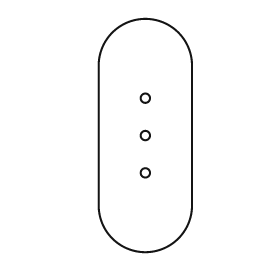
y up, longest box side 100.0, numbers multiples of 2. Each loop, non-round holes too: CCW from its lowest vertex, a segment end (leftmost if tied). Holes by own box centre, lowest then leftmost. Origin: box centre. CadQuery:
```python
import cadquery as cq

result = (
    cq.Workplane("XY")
    .moveTo(-20.0, -30.0)
    .threePointArc((0.0, -50.0), (20.0, -30.0))
    .lineTo(20.0, 30.0)
    .threePointArc((0.0, 50.0), (-20.0, 30.0))
    .close()
    .moveTo(0.0, -16.0)
    .circle(2.0)
    .moveTo(0.0, 0.0)
    .circle(2.0)
    .moveTo(0.0, 16.0)
    .circle(2.0)
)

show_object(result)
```